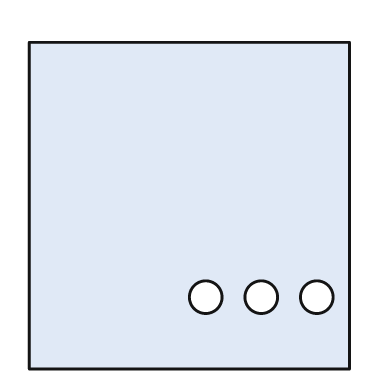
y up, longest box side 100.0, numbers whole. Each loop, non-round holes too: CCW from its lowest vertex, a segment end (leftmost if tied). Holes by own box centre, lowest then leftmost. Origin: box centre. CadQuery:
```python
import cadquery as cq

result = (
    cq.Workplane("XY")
    .moveTo(-49.0, -50.0)
    .lineTo(49.0, -50.0)
    .lineTo(49.0, 50.0)
    .lineTo(-49.0, 50.0)
    .close()
    .moveTo(5.0, -28.0)
    .circle(5.0)
    .moveTo(22.0, -28.0)
    .circle(5.0)
    .moveTo(39.0, -28.0)
    .circle(5.0)
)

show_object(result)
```